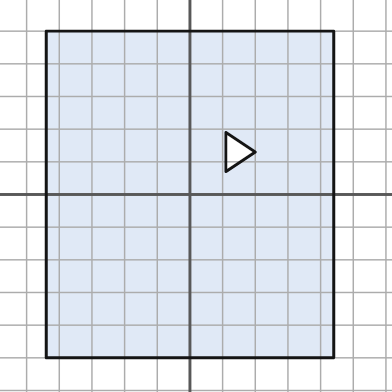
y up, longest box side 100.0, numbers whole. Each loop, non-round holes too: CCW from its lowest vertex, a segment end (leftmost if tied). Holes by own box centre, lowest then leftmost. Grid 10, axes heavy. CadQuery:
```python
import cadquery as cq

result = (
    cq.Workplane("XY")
    .moveTo(-44.0, -50.0)
    .lineTo(44.0, -50.0)
    .lineTo(44.0, 50.0)
    .lineTo(-44.0, 50.0)
    .close()
    .moveTo(11.0, 7.0)
    .lineTo(20.0, 13.0)
    .lineTo(11.0, 19.0)
    .close()
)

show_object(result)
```